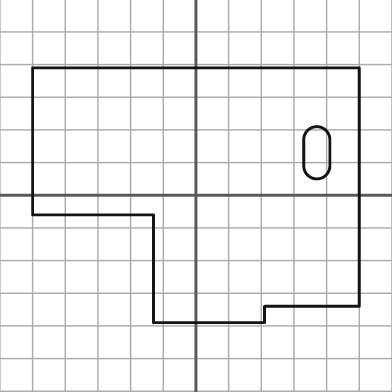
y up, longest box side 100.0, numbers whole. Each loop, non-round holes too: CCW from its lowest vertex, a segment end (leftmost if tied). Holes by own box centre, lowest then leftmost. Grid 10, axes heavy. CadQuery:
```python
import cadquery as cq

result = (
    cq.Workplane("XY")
    .moveTo(-13.0, -39.0)
    .lineTo(21.0, -39.0)
    .lineTo(21.0, -34.0)
    .lineTo(50.0, -34.0)
    .lineTo(50.0, 39.0)
    .lineTo(-50.0, 39.0)
    .lineTo(-50.0, -6.0)
    .lineTo(-13.0, -6.0)
    .close()
    .moveTo(33.0, 9.0)
    .threePointArc((37.0, 5.0), (41.0, 9.0))
    .lineTo(41.0, 17.0)
    .threePointArc((37.0, 21.0), (33.0, 17.0))
    .close()
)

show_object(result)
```